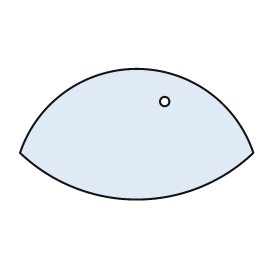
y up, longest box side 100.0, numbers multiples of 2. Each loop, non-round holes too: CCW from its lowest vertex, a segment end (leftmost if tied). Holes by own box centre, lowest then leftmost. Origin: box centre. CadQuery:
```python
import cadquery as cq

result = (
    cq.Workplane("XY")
    .moveTo(-50.0, -8.0)
    .threePointArc((0.0, -28.0), (50.0, -8.0))
    .threePointArc((0.0, 28.0), (-50.0, -8.0))
    .close()
    .moveTo(12.0, 14.0)
    .circle(2.0)
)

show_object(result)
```